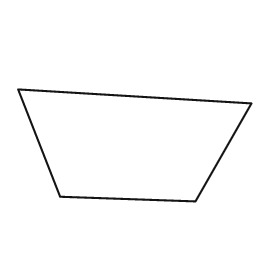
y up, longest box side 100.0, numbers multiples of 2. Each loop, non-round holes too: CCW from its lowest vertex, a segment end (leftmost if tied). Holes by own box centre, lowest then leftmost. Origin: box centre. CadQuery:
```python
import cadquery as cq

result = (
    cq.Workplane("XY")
    .moveTo(26.0, -24.0)
    .lineTo(50.0, 18.0)
    .lineTo(-50.0, 24.0)
    .lineTo(-32.0, -22.0)
    .close()
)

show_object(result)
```